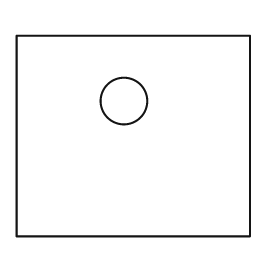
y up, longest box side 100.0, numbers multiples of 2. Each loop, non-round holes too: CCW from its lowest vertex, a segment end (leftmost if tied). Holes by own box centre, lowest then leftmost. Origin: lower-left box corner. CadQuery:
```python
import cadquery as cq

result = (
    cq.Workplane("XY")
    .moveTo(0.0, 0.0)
    .lineTo(100.0, 0.0)
    .lineTo(100.0, 86.0)
    .lineTo(0.0, 86.0)
    .close()
    .moveTo(46.0, 58.0)
    .circle(10.0)
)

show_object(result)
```